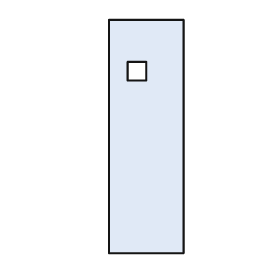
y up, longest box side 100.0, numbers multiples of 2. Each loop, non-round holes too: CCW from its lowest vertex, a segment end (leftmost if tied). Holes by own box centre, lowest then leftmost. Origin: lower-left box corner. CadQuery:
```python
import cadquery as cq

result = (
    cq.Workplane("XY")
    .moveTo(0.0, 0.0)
    .lineTo(32.0, 0.0)
    .lineTo(32.0, 100.0)
    .lineTo(0.0, 100.0)
    .close()
    .moveTo(8.0, 74.0)
    .lineTo(16.0, 74.0)
    .lineTo(16.0, 82.0)
    .lineTo(8.0, 82.0)
    .close()
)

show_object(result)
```